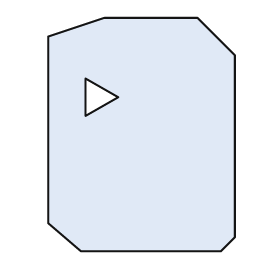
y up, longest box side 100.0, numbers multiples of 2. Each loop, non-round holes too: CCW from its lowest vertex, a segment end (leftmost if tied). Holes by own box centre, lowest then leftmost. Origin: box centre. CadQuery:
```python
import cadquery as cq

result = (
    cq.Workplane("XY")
    .moveTo(-26.0, -50.0)
    .lineTo(34.0, -50.0)
    .lineTo(40.0, -44.0)
    .lineTo(40.0, 34.0)
    .lineTo(24.0, 50.0)
    .lineTo(-16.0, 50.0)
    .lineTo(-40.0, 42.0)
    .lineTo(-40.0, -38.0)
    .close()
    .moveTo(-24.0, 8.0)
    .lineTo(-10.0, 16.0)
    .lineTo(-24.0, 24.0)
    .close()
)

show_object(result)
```